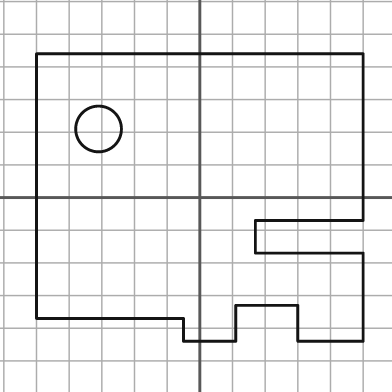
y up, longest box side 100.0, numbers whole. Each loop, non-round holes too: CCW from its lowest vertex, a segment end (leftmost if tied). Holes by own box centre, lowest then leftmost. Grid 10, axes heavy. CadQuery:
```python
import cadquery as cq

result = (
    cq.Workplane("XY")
    .moveTo(-5.0, -44.0)
    .lineTo(11.0, -44.0)
    .lineTo(11.0, -33.0)
    .lineTo(30.0, -33.0)
    .lineTo(30.0, -44.0)
    .lineTo(50.0, -44.0)
    .lineTo(50.0, -17.0)
    .lineTo(17.0, -17.0)
    .lineTo(17.0, -7.0)
    .lineTo(50.0, -7.0)
    .lineTo(50.0, 44.0)
    .lineTo(-50.0, 44.0)
    .lineTo(-50.0, -37.0)
    .lineTo(-5.0, -37.0)
    .close()
    .moveTo(-31.0, 21.0)
    .circle(7.0)
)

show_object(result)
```